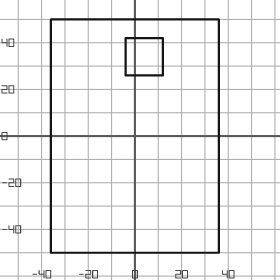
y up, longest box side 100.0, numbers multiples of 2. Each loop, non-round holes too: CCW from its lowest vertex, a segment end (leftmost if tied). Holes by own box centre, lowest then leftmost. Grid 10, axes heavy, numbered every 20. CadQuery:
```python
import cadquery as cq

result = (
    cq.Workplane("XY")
    .moveTo(-36.0, -50.0)
    .lineTo(36.0, -50.0)
    .lineTo(36.0, 50.0)
    .lineTo(-36.0, 50.0)
    .close()
    .moveTo(-4.0, 26.0)
    .lineTo(12.0, 26.0)
    .lineTo(12.0, 42.0)
    .lineTo(-4.0, 42.0)
    .close()
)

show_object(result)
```